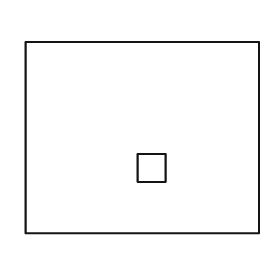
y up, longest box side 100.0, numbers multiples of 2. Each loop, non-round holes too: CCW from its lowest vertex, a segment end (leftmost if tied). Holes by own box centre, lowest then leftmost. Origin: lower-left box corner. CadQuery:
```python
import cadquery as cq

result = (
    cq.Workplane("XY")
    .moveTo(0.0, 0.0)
    .lineTo(100.0, 0.0)
    .lineTo(100.0, 82.0)
    .lineTo(0.0, 82.0)
    .close()
    .moveTo(48.0, 22.0)
    .lineTo(60.0, 22.0)
    .lineTo(60.0, 34.0)
    .lineTo(48.0, 34.0)
    .close()
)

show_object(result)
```